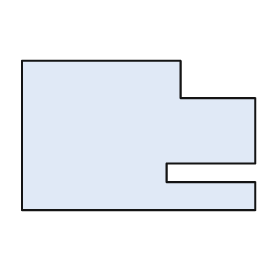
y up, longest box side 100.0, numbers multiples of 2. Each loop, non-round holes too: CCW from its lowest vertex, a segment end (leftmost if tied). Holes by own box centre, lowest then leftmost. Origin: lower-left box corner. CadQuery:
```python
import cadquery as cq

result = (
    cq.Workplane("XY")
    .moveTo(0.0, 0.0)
    .lineTo(100.0, 0.0)
    .lineTo(100.0, 12.0)
    .lineTo(62.0, 12.0)
    .lineTo(62.0, 20.0)
    .lineTo(100.0, 20.0)
    .lineTo(100.0, 48.0)
    .lineTo(68.0, 48.0)
    .lineTo(68.0, 64.0)
    .lineTo(0.0, 64.0)
    .close()
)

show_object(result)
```